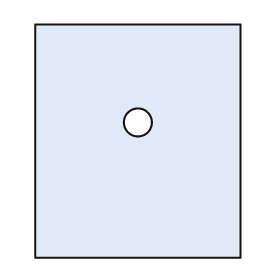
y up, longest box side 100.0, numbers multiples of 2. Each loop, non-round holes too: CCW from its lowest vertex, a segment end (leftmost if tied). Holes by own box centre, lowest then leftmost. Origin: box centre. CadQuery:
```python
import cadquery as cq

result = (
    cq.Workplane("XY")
    .moveTo(-44.0, -50.0)
    .lineTo(44.0, -50.0)
    .lineTo(44.0, 50.0)
    .lineTo(-44.0, 50.0)
    .close()
    .moveTo(0.0, 8.0)
    .circle(6.0)
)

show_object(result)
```